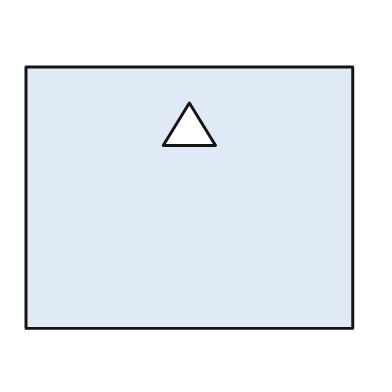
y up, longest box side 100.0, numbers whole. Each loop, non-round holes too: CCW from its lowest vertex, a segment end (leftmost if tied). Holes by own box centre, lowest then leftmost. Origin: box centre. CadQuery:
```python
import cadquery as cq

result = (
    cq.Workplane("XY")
    .moveTo(-50.0, -40.0)
    .lineTo(50.0, -40.0)
    .lineTo(50.0, 40.0)
    .lineTo(-50.0, 40.0)
    .close()
    .moveTo(-8.0, 16.0)
    .lineTo(8.0, 16.0)
    .lineTo(0.0, 29.0)
    .close()
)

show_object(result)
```